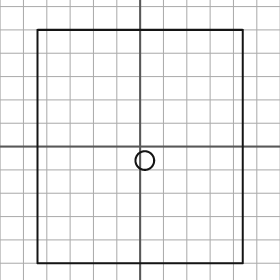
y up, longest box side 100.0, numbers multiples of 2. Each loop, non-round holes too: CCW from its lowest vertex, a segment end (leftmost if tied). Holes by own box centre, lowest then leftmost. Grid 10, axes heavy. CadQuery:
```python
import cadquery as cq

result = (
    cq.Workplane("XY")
    .moveTo(-44.0, -50.0)
    .lineTo(44.0, -50.0)
    .lineTo(44.0, 50.0)
    .lineTo(-44.0, 50.0)
    .close()
    .moveTo(2.0, -6.0)
    .circle(4.0)
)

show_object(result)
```